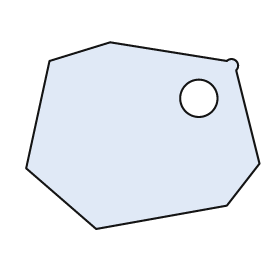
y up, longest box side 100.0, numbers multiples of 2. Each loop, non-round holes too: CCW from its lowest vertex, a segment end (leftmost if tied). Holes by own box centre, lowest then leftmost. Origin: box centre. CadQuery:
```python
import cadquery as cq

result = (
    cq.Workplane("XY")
    .moveTo(-20.0, -40.0)
    .lineTo(36.0, -30.0)
    .lineTo(50.0, -12.0)
    .lineTo(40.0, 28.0)
    .threePointArc((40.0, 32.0), (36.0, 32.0))
    .lineTo(-14.0, 40.0)
    .lineTo(-40.0, 32.0)
    .lineTo(-50.0, -14.0)
    .close()
    .moveTo(24.0, 16.0)
    .circle(8.0)
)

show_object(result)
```